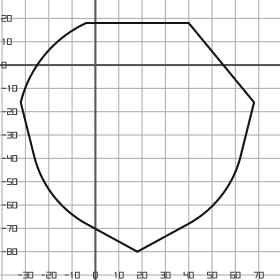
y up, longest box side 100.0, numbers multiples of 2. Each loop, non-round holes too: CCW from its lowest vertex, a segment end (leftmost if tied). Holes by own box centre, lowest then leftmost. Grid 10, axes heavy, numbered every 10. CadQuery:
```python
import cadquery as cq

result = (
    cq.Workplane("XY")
    .moveTo(18.0, -80.0)
    .lineTo(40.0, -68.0)
    .threePointArc((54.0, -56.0), (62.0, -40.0))
    .lineTo(68.0, -16.0)
    .lineTo(40.0, 18.0)
    .lineTo(-4.0, 18.0)
    .threePointArc((-22.0, 4.0), (-32.0, -16.0))
    .lineTo(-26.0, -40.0)
    .threePointArc((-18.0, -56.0), (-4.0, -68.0))
    .close()
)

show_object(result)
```